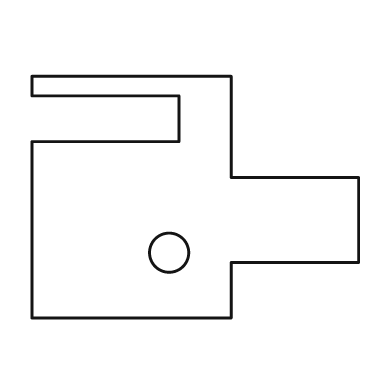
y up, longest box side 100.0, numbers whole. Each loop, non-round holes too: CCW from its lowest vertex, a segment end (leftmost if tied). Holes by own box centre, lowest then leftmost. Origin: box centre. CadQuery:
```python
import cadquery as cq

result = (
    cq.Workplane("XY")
    .moveTo(-50.0, -37.0)
    .lineTo(11.0, -37.0)
    .lineTo(11.0, -20.0)
    .lineTo(50.0, -20.0)
    .lineTo(50.0, 6.0)
    .lineTo(11.0, 6.0)
    .lineTo(11.0, 37.0)
    .lineTo(-50.0, 37.0)
    .lineTo(-50.0, 31.0)
    .lineTo(-5.0, 31.0)
    .lineTo(-5.0, 17.0)
    .lineTo(-50.0, 17.0)
    .close()
    .moveTo(-8.0, -17.0)
    .circle(6.0)
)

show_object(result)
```